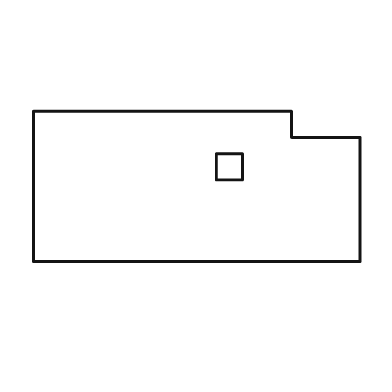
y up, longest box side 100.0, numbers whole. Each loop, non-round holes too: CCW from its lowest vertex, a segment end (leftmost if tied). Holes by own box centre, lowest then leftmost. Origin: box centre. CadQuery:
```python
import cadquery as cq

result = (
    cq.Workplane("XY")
    .moveTo(-50.0, -23.0)
    .lineTo(50.0, -23.0)
    .lineTo(50.0, 15.0)
    .lineTo(29.0, 15.0)
    .lineTo(29.0, 23.0)
    .lineTo(-50.0, 23.0)
    .close()
    .moveTo(6.0, 2.0)
    .lineTo(14.0, 2.0)
    .lineTo(14.0, 10.0)
    .lineTo(6.0, 10.0)
    .close()
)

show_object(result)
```